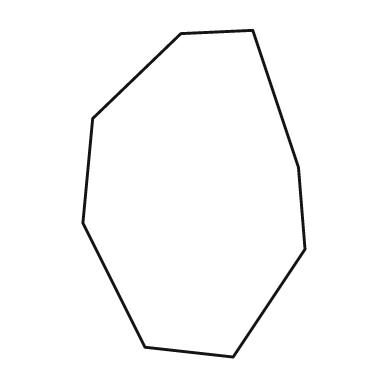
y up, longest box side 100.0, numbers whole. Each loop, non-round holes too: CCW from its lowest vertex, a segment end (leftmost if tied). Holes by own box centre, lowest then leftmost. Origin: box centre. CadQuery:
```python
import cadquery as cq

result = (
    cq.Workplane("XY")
    .moveTo(12.0, -50.0)
    .lineTo(34.0, -17.0)
    .lineTo(32.0, 8.0)
    .lineTo(18.0, 50.0)
    .lineTo(-4.0, 49.0)
    .lineTo(-31.0, 23.0)
    .lineTo(-34.0, -9.0)
    .lineTo(-15.0, -47.0)
    .close()
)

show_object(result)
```